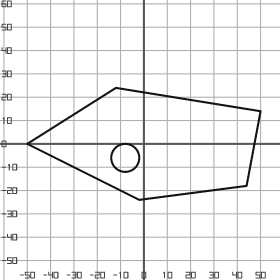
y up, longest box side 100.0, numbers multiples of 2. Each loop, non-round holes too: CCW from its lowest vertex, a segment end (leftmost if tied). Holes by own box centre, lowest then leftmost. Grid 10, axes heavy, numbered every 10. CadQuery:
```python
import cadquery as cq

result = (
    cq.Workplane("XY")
    .moveTo(-2.0, -24.0)
    .lineTo(44.0, -18.0)
    .lineTo(50.0, 14.0)
    .lineTo(-12.0, 24.0)
    .lineTo(-50.0, 0.0)
    .close()
    .moveTo(-8.0, -6.0)
    .circle(6.0)
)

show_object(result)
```